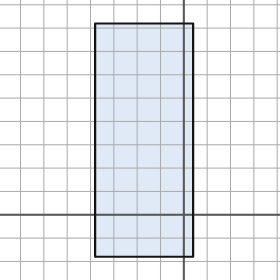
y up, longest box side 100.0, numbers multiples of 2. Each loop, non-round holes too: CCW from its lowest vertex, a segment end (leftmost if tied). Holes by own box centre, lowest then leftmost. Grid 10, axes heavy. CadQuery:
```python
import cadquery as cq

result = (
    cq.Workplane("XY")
    .moveTo(-38.0, -18.0)
    .lineTo(4.0, -18.0)
    .lineTo(4.0, 82.0)
    .lineTo(-38.0, 82.0)
    .close()
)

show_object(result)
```